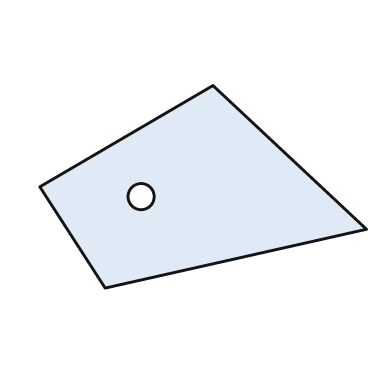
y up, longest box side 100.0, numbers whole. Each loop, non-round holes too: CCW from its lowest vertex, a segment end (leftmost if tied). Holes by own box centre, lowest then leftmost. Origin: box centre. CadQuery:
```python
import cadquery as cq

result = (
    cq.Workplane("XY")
    .moveTo(-30.0, -31.0)
    .lineTo(50.0, -13.0)
    .lineTo(3.0, 31.0)
    .lineTo(-50.0, 0.0)
    .close()
    .moveTo(-19.0, -3.0)
    .circle(4.0)
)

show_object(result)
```